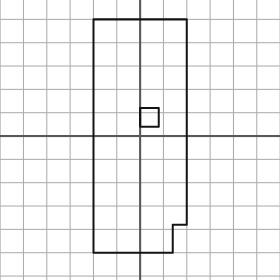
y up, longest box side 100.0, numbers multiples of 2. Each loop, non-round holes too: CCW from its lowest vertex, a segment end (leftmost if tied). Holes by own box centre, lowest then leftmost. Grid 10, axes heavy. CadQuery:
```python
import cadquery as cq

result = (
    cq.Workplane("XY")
    .moveTo(-20.0, -50.0)
    .lineTo(14.0, -50.0)
    .lineTo(14.0, -38.0)
    .lineTo(20.0, -38.0)
    .lineTo(20.0, 50.0)
    .lineTo(-20.0, 50.0)
    .close()
    .moveTo(0.0, 4.0)
    .lineTo(8.0, 4.0)
    .lineTo(8.0, 12.0)
    .lineTo(0.0, 12.0)
    .close()
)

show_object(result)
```